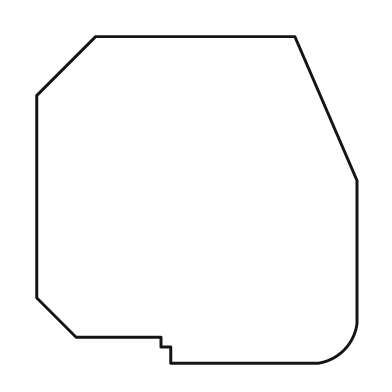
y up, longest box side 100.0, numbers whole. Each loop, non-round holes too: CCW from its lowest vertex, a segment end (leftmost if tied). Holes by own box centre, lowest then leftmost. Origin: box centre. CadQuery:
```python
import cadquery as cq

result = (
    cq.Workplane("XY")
    .moveTo(-8.0, -50.0)
    .lineTo(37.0, -50.0)
    .threePointArc((45.0, -46.0), (49.0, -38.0))
    .lineTo(49.0, 6.0)
    .lineTo(30.0, 50.0)
    .lineTo(-31.0, 50.0)
    .lineTo(-49.0, 32.0)
    .lineTo(-49.0, -30.0)
    .lineTo(-37.0, -42.0)
    .lineTo(-11.0, -42.0)
    .lineTo(-11.0, -45.0)
    .lineTo(-8.0, -45.0)
    .close()
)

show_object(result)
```